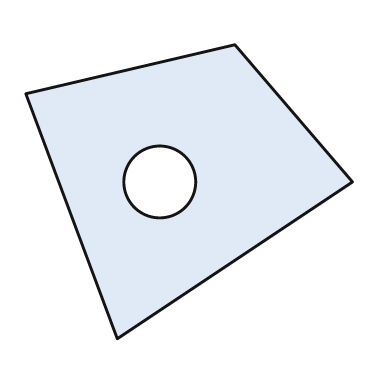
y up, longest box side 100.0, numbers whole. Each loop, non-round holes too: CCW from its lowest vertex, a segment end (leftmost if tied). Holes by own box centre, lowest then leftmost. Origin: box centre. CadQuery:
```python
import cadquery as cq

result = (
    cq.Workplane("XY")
    .moveTo(-22.0, -45.0)
    .lineTo(50.0, 3.0)
    .lineTo(14.0, 45.0)
    .lineTo(-50.0, 30.0)
    .close()
    .moveTo(-9.0, 3.0)
    .circle(11.0)
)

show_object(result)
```